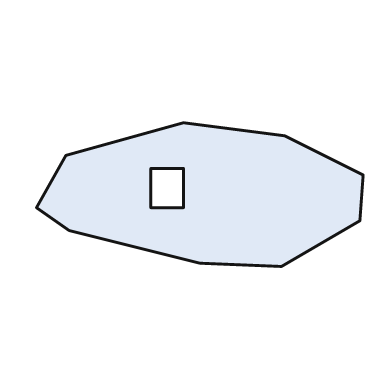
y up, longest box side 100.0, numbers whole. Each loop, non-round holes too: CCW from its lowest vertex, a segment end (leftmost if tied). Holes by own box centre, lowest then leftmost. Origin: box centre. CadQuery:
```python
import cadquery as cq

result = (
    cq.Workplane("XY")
    .moveTo(25.0, -22.0)
    .lineTo(49.0, -8.0)
    .lineTo(50.0, 6.0)
    .lineTo(26.0, 18.0)
    .lineTo(-5.0, 22.0)
    .lineTo(-41.0, 12.0)
    .lineTo(-50.0, -4.0)
    .lineTo(-40.0, -11.0)
    .lineTo(0.0, -21.0)
    .close()
    .moveTo(-15.0, -4.0)
    .lineTo(-5.0, -4.0)
    .lineTo(-5.0, 8.0)
    .lineTo(-15.0, 8.0)
    .close()
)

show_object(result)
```